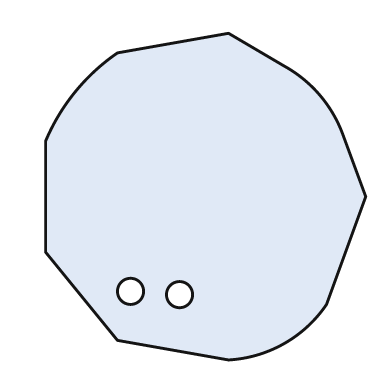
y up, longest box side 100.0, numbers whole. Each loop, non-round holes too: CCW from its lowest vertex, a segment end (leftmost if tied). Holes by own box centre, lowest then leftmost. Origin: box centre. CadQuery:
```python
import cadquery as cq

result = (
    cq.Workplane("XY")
    .moveTo(7.0, -50.0)
    .threePointArc((24.0, -45.0), (37.0, -33.0))
    .lineTo(49.0, 0.0)
    .lineTo(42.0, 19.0)
    .threePointArc((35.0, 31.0), (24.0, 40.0))
    .lineTo(7.0, 50.0)
    .lineTo(-27.0, 44.0)
    .threePointArc((-40.0, 32.0), (-49.0, 17.0))
    .lineTo(-49.0, -17.0)
    .lineTo(-27.0, -44.0)
    .close()
    .moveTo(-8.0, -30.0)
    .circle(4.0)
    .moveTo(-23.0, -29.0)
    .circle(4.0)
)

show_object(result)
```